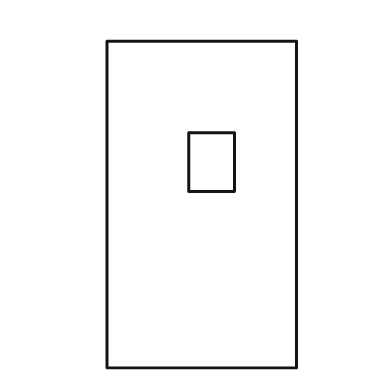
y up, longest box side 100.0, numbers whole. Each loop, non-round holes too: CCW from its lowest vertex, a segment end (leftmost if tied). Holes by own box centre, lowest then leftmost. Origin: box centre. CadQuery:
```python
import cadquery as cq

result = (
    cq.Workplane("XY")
    .moveTo(-29.0, -50.0)
    .lineTo(29.0, -50.0)
    .lineTo(29.0, 50.0)
    .lineTo(-29.0, 50.0)
    .close()
    .moveTo(-4.0, 4.0)
    .lineTo(10.0, 4.0)
    .lineTo(10.0, 22.0)
    .lineTo(-4.0, 22.0)
    .close()
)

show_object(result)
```